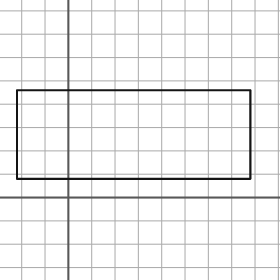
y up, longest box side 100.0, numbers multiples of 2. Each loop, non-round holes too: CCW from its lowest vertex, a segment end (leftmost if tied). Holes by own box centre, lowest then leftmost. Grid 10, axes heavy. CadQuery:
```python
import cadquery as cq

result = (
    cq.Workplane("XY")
    .moveTo(-22.0, 8.0)
    .lineTo(78.0, 8.0)
    .lineTo(78.0, 46.0)
    .lineTo(-22.0, 46.0)
    .close()
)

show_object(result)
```